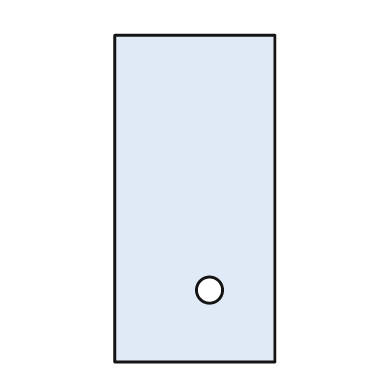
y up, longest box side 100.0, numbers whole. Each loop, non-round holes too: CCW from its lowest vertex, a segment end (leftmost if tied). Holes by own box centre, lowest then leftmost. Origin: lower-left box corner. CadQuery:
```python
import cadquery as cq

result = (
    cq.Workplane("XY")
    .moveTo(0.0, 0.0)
    .lineTo(49.0, 0.0)
    .lineTo(49.0, 100.0)
    .lineTo(0.0, 100.0)
    .close()
    .moveTo(29.0, 22.0)
    .circle(4.0)
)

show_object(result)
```